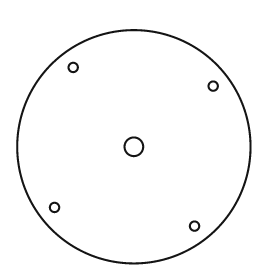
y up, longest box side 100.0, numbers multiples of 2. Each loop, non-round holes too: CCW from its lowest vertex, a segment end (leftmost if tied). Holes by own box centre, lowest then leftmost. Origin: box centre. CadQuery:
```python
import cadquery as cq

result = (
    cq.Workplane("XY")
    .moveTo(0.0, 0.0)
    .circle(50.0)
    .moveTo(26.0, -34.0)
    .circle(2.0)
    .moveTo(-34.0, -26.0)
    .circle(2.0)
    .moveTo(0.0, 0.0)
    .circle(4.0)
    .moveTo(34.0, 26.0)
    .circle(2.0)
    .moveTo(-26.0, 34.0)
    .circle(2.0)
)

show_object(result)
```